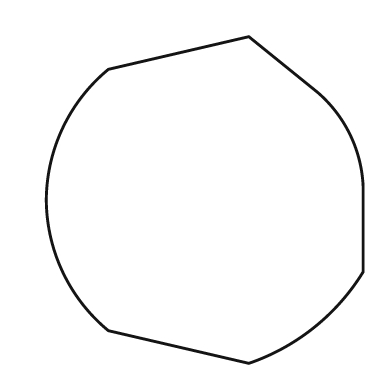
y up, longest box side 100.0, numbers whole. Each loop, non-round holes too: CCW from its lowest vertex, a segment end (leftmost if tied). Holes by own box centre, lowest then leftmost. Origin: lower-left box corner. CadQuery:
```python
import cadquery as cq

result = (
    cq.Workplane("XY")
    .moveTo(62.0, 0.0)
    .threePointArc((82.0, 11.0), (97.0, 28.0))
    .lineTo(97.0, 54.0)
    .threePointArc((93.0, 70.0), (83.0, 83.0))
    .lineTo(62.0, 100.0)
    .lineTo(19.0, 90.0)
    .threePointArc((5.0, 72.0), (0.0, 50.0))
    .threePointArc((5.0, 28.0), (19.0, 10.0))
    .close()
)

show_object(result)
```